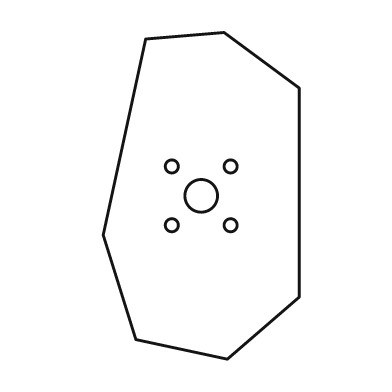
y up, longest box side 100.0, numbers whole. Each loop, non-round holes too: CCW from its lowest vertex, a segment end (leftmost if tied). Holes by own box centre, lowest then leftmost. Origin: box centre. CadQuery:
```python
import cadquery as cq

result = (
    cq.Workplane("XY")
    .moveTo(8.0, -50.0)
    .lineTo(30.0, -31.0)
    .lineTo(30.0, 33.0)
    .lineTo(7.0, 50.0)
    .lineTo(-17.0, 48.0)
    .lineTo(-30.0, -12.0)
    .lineTo(-20.0, -44.0)
    .close()
    .moveTo(-9.0, -9.0)
    .circle(2.0)
    .moveTo(9.0, -9.0)
    .circle(2.0)
    .moveTo(0.0, 0.0)
    .circle(5.0)
    .moveTo(-9.0, 9.0)
    .circle(2.0)
    .moveTo(9.0, 9.0)
    .circle(2.0)
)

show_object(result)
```